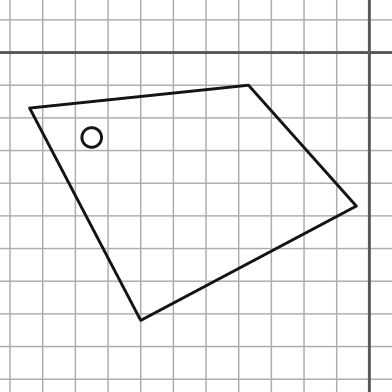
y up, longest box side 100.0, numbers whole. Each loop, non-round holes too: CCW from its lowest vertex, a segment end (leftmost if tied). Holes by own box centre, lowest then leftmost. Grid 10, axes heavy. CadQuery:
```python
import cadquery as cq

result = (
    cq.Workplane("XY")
    .moveTo(-70.0, -82.0)
    .lineTo(-4.0, -47.0)
    .lineTo(-37.0, -10.0)
    .lineTo(-104.0, -17.0)
    .close()
    .moveTo(-85.0, -26.0)
    .circle(3.0)
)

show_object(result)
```